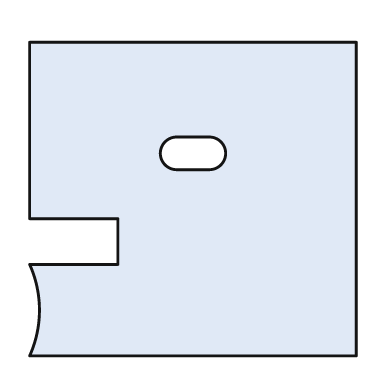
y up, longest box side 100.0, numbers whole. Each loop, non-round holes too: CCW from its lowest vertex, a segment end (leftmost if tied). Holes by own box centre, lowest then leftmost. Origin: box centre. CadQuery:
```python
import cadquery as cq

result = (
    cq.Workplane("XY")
    .moveTo(-50.0, -48.0)
    .lineTo(50.0, -48.0)
    .lineTo(50.0, 48.0)
    .lineTo(-50.0, 48.0)
    .lineTo(-50.0, -6.0)
    .lineTo(-23.0, -6.0)
    .lineTo(-23.0, -20.0)
    .lineTo(-50.0, -20.0)
    .threePointArc((-47.0, -34.0), (-50.0, -48.0))
    .close()
    .moveTo(-5.0, 9.0)
    .lineTo(5.0, 9.0)
    .threePointArc((10.0, 14.0), (5.0, 19.0))
    .lineTo(-5.0, 19.0)
    .threePointArc((-10.0, 14.0), (-5.0, 9.0))
    .close()
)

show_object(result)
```